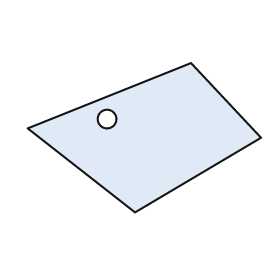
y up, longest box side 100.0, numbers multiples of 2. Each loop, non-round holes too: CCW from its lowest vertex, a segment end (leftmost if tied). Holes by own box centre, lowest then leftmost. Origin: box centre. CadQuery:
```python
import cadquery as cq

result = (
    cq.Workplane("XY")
    .moveTo(-4.0, -32.0)
    .lineTo(50.0, 0.0)
    .lineTo(20.0, 32.0)
    .lineTo(-50.0, 4.0)
    .close()
    .moveTo(-16.0, 8.0)
    .circle(4.0)
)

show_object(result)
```